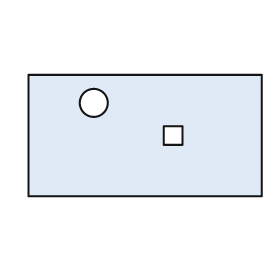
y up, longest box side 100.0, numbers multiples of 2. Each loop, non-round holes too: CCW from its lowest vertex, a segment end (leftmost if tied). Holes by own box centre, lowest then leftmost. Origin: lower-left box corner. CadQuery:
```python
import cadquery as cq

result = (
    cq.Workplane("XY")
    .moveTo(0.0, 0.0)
    .lineTo(100.0, 0.0)
    .lineTo(100.0, 52.0)
    .lineTo(0.0, 52.0)
    .close()
    .moveTo(58.0, 22.0)
    .lineTo(66.0, 22.0)
    .lineTo(66.0, 30.0)
    .lineTo(58.0, 30.0)
    .close()
    .moveTo(28.0, 40.0)
    .circle(6.0)
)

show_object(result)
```